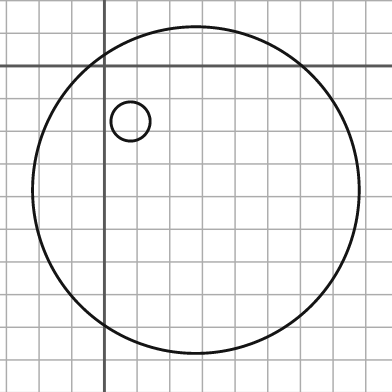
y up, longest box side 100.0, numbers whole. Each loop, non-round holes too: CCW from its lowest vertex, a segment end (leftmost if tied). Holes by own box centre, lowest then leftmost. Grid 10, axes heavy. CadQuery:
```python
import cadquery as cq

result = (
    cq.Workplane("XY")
    .moveTo(28.0, -38.0)
    .circle(50.0)
    .moveTo(8.0, -17.0)
    .circle(6.0)
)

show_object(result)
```